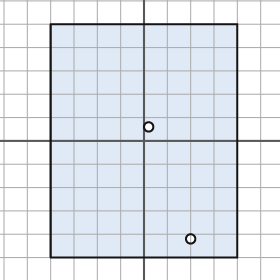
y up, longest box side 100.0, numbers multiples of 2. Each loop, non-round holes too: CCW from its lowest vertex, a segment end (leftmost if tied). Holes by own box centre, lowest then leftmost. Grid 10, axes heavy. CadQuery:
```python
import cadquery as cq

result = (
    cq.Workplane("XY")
    .moveTo(-40.0, -50.0)
    .lineTo(40.0, -50.0)
    .lineTo(40.0, 50.0)
    .lineTo(-40.0, 50.0)
    .close()
    .moveTo(20.0, -42.0)
    .circle(2.0)
    .moveTo(2.0, 6.0)
    .circle(2.0)
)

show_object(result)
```